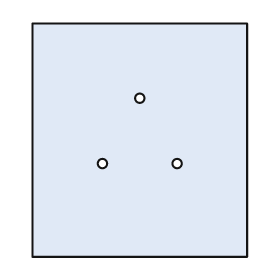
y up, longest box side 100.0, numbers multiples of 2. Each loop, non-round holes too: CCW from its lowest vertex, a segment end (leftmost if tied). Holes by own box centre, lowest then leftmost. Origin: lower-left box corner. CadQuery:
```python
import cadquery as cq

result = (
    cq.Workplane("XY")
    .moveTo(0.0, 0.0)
    .lineTo(92.0, 0.0)
    .lineTo(92.0, 100.0)
    .lineTo(0.0, 100.0)
    .close()
    .moveTo(30.0, 40.0)
    .circle(2.0)
    .moveTo(62.0, 40.0)
    .circle(2.0)
    .moveTo(46.0, 68.0)
    .circle(2.0)
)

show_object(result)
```